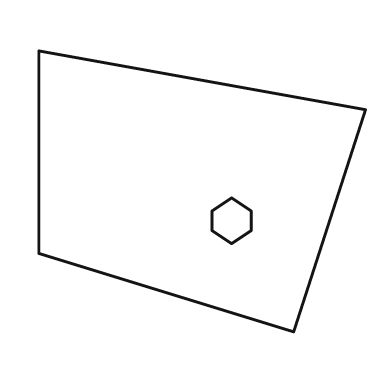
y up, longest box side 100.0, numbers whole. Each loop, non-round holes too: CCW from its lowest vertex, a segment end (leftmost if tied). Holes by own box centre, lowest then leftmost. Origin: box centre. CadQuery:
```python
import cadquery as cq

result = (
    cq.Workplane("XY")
    .moveTo(28.0, -43.0)
    .lineTo(50.0, 25.0)
    .lineTo(-50.0, 43.0)
    .lineTo(-50.0, -19.0)
    .close()
    .moveTo(9.0, -16.0)
    .lineTo(15.0, -12.0)
    .lineTo(15.0, -6.0)
    .lineTo(9.0, -2.0)
    .lineTo(3.0, -6.0)
    .lineTo(3.0, -12.0)
    .close()
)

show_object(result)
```